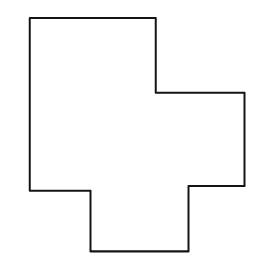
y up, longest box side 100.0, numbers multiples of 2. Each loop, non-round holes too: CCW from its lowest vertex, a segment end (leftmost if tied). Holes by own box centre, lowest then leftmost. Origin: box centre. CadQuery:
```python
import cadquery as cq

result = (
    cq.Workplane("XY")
    .moveTo(-20.0, -50.0)
    .lineTo(22.0, -50.0)
    .lineTo(22.0, -22.0)
    .lineTo(46.0, -22.0)
    .lineTo(46.0, 18.0)
    .lineTo(8.0, 18.0)
    .lineTo(8.0, 50.0)
    .lineTo(-46.0, 50.0)
    .lineTo(-46.0, -24.0)
    .lineTo(-20.0, -24.0)
    .close()
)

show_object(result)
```